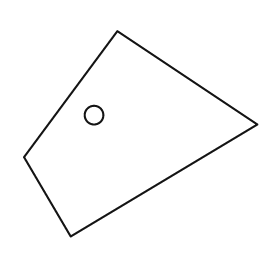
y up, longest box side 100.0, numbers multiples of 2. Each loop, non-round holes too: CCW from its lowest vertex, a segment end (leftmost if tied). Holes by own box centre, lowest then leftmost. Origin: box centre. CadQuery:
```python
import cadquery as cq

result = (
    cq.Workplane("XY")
    .moveTo(-30.0, -44.0)
    .lineTo(50.0, 4.0)
    .lineTo(-10.0, 44.0)
    .lineTo(-50.0, -10.0)
    .close()
    .moveTo(-20.0, 8.0)
    .circle(4.0)
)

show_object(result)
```